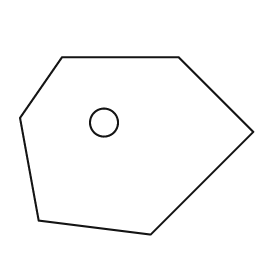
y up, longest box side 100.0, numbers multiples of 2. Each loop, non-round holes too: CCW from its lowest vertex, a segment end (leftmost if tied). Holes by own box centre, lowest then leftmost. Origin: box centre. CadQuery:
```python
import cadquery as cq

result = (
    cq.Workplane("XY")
    .moveTo(6.0, -38.0)
    .lineTo(50.0, 6.0)
    .lineTo(18.0, 38.0)
    .lineTo(-32.0, 38.0)
    .lineTo(-50.0, 12.0)
    .lineTo(-42.0, -32.0)
    .close()
    .moveTo(-14.0, 10.0)
    .circle(6.0)
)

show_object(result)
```